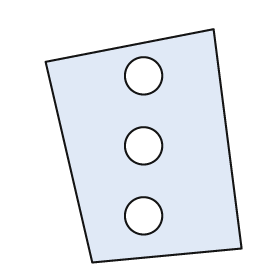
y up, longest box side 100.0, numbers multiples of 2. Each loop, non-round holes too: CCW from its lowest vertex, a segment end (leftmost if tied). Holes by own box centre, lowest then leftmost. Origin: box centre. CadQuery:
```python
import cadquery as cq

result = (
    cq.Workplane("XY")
    .moveTo(-22.0, -50.0)
    .lineTo(42.0, -44.0)
    .lineTo(30.0, 50.0)
    .lineTo(-42.0, 36.0)
    .close()
    .moveTo(0.0, -30.0)
    .circle(8.0)
    .moveTo(0.0, 0.0)
    .circle(8.0)
    .moveTo(0.0, 30.0)
    .circle(8.0)
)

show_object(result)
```